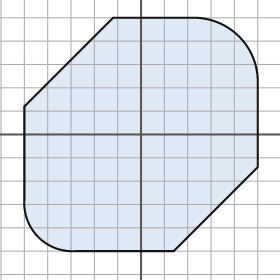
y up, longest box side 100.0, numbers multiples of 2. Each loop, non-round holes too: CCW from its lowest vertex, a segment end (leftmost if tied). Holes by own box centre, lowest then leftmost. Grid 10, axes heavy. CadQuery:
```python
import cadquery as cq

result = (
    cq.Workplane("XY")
    .moveTo(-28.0, -50.0)
    .lineTo(14.0, -50.0)
    .lineTo(50.0, -14.0)
    .lineTo(50.0, 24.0)
    .threePointArc((42.0, 42.0), (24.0, 50.0))
    .lineTo(-12.0, 50.0)
    .lineTo(-50.0, 12.0)
    .lineTo(-50.0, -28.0)
    .threePointArc((-44.0, -44.0), (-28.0, -50.0))
    .close()
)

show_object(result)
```